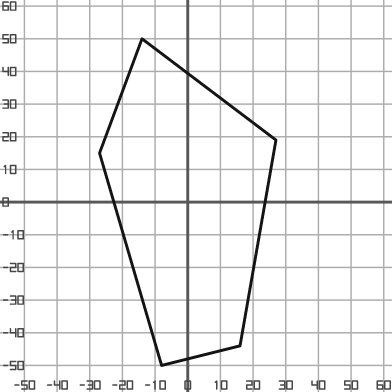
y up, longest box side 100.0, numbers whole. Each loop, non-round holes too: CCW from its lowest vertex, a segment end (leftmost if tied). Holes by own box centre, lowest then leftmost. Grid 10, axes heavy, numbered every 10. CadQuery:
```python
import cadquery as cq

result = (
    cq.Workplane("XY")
    .moveTo(-8.0, -50.0)
    .lineTo(16.0, -44.0)
    .lineTo(27.0, 19.0)
    .lineTo(-14.0, 50.0)
    .lineTo(-27.0, 15.0)
    .close()
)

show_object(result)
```